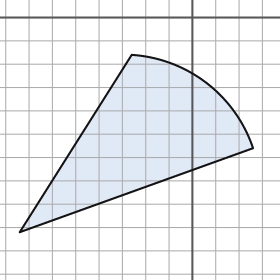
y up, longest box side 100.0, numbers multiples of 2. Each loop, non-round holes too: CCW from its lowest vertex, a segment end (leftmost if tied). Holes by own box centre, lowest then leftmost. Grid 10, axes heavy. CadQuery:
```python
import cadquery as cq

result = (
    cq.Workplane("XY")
    .moveTo(-74.0, -92.0)
    .lineTo(26.0, -56.0)
    .threePointArc((6.0, -28.0), (-26.0, -16.0))
    .close()
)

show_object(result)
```